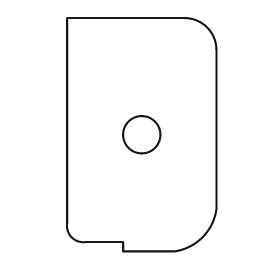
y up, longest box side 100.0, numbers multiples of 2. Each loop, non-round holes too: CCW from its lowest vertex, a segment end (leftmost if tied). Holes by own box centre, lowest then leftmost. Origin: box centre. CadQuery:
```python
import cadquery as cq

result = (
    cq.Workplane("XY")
    .moveTo(-8.0, -50.0)
    .lineTo(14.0, -50.0)
    .threePointArc((26.0, -44.0), (32.0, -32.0))
    .lineTo(32.0, 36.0)
    .threePointArc((28.0, 46.0), (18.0, 50.0))
    .lineTo(-32.0, 50.0)
    .lineTo(-32.0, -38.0)
    .threePointArc((-30.0, -44.0), (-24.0, -46.0))
    .lineTo(-8.0, -46.0)
    .close()
    .moveTo(0.0, 0.0)
    .circle(8.0)
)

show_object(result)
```